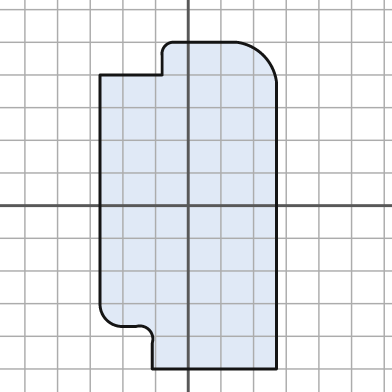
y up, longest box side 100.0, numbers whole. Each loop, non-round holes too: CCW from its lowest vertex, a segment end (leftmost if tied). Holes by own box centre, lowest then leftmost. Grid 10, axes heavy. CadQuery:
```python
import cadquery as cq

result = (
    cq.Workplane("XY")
    .moveTo(-11.0, -50.0)
    .lineTo(27.0, -50.0)
    .lineTo(27.0, 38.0)
    .threePointArc((23.0, 46.0), (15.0, 50.0))
    .lineTo(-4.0, 50.0)
    .threePointArc((-7.0, 49.0), (-8.0, 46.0))
    .lineTo(-8.0, 40.0)
    .lineTo(-27.0, 40.0)
    .lineTo(-27.0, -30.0)
    .threePointArc((-25.0, -35.0), (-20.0, -37.0))
    .lineTo(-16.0, -37.0)
    .threePointArc((-12.0, -38.0), (-11.0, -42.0))
    .close()
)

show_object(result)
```